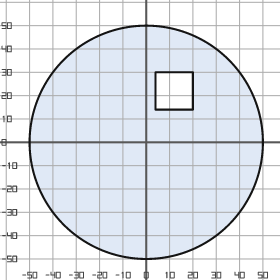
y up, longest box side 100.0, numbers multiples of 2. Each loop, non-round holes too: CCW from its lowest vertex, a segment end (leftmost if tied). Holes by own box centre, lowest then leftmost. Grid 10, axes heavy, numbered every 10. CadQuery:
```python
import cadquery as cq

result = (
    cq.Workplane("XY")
    .moveTo(0.0, 0.0)
    .circle(50.0)
    .moveTo(4.0, 14.0)
    .lineTo(20.0, 14.0)
    .lineTo(20.0, 30.0)
    .lineTo(4.0, 30.0)
    .close()
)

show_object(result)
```